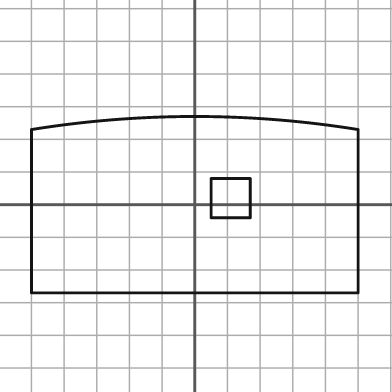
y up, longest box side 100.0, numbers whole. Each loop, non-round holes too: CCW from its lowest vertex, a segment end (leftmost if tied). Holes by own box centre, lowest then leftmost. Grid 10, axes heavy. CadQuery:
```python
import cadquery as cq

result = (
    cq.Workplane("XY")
    .moveTo(-50.0, -27.0)
    .lineTo(50.0, -27.0)
    .lineTo(50.0, 23.0)
    .threePointArc((0.0, 27.0), (-50.0, 23.0))
    .close()
    .moveTo(5.0, -4.0)
    .lineTo(17.0, -4.0)
    .lineTo(17.0, 8.0)
    .lineTo(5.0, 8.0)
    .close()
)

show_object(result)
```